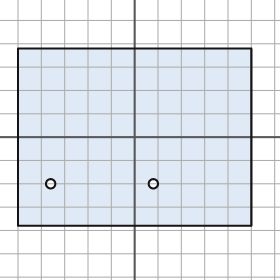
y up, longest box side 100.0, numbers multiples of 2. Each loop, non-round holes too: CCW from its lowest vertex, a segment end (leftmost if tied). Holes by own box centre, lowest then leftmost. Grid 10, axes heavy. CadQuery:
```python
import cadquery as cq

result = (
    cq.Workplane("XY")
    .moveTo(-50.0, -38.0)
    .lineTo(50.0, -38.0)
    .lineTo(50.0, 38.0)
    .lineTo(-50.0, 38.0)
    .close()
    .moveTo(-36.0, -20.0)
    .circle(2.0)
    .moveTo(8.0, -20.0)
    .circle(2.0)
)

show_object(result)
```